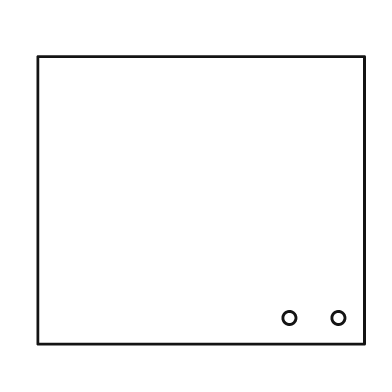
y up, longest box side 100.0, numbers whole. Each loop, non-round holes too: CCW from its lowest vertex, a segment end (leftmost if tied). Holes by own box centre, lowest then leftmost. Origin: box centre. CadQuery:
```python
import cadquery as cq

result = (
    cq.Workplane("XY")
    .moveTo(-50.0, -44.0)
    .lineTo(50.0, -44.0)
    .lineTo(50.0, 44.0)
    .lineTo(-50.0, 44.0)
    .close()
    .moveTo(27.0, -36.0)
    .circle(2.0)
    .moveTo(42.0, -36.0)
    .circle(2.0)
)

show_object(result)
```